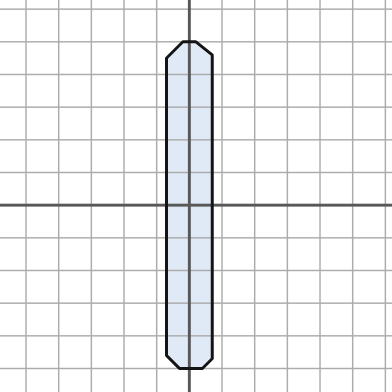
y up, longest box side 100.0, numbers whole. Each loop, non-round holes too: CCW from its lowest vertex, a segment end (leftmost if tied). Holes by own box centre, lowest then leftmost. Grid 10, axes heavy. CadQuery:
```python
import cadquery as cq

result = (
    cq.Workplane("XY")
    .moveTo(-3.0, -50.0)
    .lineTo(4.0, -50.0)
    .lineTo(7.0, -47.0)
    .lineTo(7.0, 46.0)
    .lineTo(2.0, 50.0)
    .lineTo(-2.0, 50.0)
    .lineTo(-7.0, 45.0)
    .lineTo(-7.0, -46.0)
    .close()
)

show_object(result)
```